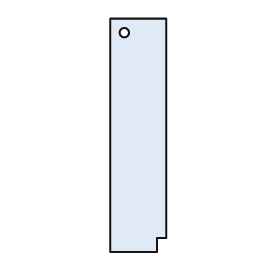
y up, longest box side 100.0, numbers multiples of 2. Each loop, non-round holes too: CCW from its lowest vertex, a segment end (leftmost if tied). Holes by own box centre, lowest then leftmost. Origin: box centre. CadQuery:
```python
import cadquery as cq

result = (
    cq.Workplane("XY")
    .moveTo(-12.0, -50.0)
    .lineTo(8.0, -50.0)
    .lineTo(8.0, -44.0)
    .lineTo(12.0, -44.0)
    .lineTo(12.0, 50.0)
    .lineTo(-12.0, 50.0)
    .close()
    .moveTo(-6.0, 44.0)
    .circle(2.0)
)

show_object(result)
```